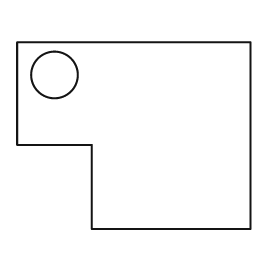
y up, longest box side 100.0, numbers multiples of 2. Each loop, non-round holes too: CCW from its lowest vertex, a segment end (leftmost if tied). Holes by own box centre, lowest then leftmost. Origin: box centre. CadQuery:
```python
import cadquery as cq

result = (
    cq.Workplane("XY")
    .moveTo(-18.0, -40.0)
    .lineTo(50.0, -40.0)
    .lineTo(50.0, 40.0)
    .lineTo(-50.0, 40.0)
    .lineTo(-50.0, -4.0)
    .lineTo(-18.0, -4.0)
    .close()
    .moveTo(-34.0, 26.0)
    .circle(10.0)
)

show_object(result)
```